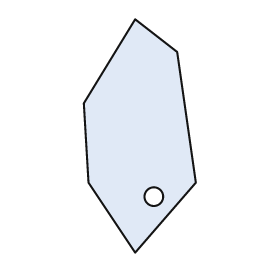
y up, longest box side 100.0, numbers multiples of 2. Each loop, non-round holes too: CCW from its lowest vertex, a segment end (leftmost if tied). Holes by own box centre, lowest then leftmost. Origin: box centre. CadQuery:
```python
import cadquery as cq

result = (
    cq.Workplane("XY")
    .moveTo(-2.0, -50.0)
    .lineTo(24.0, -20.0)
    .lineTo(16.0, 36.0)
    .lineTo(-2.0, 50.0)
    .lineTo(-24.0, 14.0)
    .lineTo(-22.0, -20.0)
    .close()
    .moveTo(6.0, -26.0)
    .circle(4.0)
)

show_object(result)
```